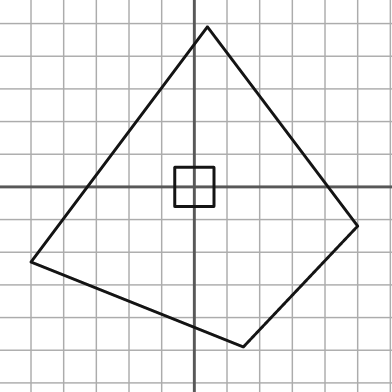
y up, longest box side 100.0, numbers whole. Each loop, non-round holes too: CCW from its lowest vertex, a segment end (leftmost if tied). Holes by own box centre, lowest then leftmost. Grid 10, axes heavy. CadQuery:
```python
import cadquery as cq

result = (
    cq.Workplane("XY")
    .moveTo(15.0, -49.0)
    .lineTo(50.0, -12.0)
    .lineTo(4.0, 49.0)
    .lineTo(-50.0, -23.0)
    .close()
    .moveTo(-6.0, -6.0)
    .lineTo(6.0, -6.0)
    .lineTo(6.0, 6.0)
    .lineTo(-6.0, 6.0)
    .close()
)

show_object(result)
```